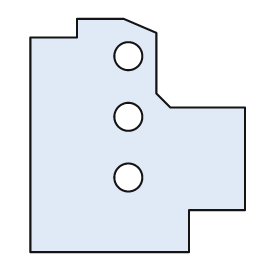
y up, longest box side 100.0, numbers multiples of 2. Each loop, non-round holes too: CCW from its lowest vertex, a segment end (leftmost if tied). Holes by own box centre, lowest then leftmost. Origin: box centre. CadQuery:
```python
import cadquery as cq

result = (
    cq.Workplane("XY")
    .moveTo(-46.0, -50.0)
    .lineTo(22.0, -50.0)
    .lineTo(22.0, -32.0)
    .lineTo(46.0, -32.0)
    .lineTo(46.0, 12.0)
    .lineTo(14.0, 12.0)
    .lineTo(8.0, 18.0)
    .lineTo(8.0, 44.0)
    .lineTo(-6.0, 50.0)
    .lineTo(-26.0, 50.0)
    .lineTo(-26.0, 42.0)
    .lineTo(-46.0, 42.0)
    .close()
    .moveTo(-4.0, -18.0)
    .circle(6.0)
    .moveTo(-4.0, 8.0)
    .circle(6.0)
    .moveTo(-4.0, 34.0)
    .circle(6.0)
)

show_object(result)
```